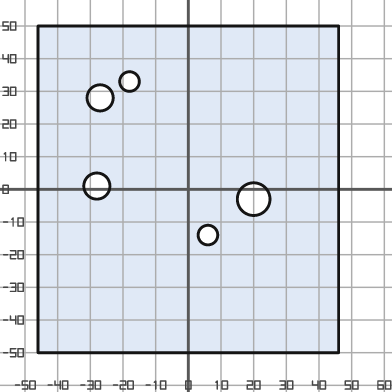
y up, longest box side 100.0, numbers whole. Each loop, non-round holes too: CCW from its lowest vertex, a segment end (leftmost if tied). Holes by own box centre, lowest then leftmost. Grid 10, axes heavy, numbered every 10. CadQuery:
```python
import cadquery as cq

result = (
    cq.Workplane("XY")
    .moveTo(-46.0, -50.0)
    .lineTo(46.0, -50.0)
    .lineTo(46.0, 50.0)
    .lineTo(-46.0, 50.0)
    .close()
    .moveTo(6.0, -14.0)
    .circle(3.0)
    .moveTo(20.0, -3.0)
    .circle(5.0)
    .moveTo(-28.0, 1.0)
    .circle(4.0)
    .moveTo(-27.0, 28.0)
    .circle(4.0)
    .moveTo(-18.0, 33.0)
    .circle(3.0)
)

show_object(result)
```